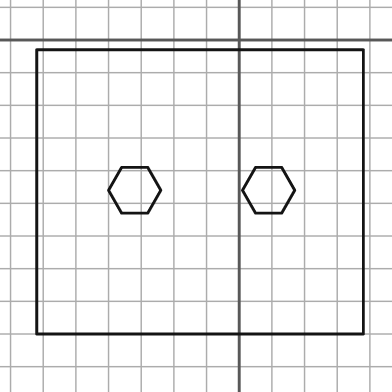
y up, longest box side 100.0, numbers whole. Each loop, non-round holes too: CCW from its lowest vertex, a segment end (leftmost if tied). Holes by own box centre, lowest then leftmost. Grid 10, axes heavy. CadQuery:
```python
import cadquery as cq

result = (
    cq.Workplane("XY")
    .moveTo(-62.0, -90.0)
    .lineTo(38.0, -90.0)
    .lineTo(38.0, -3.0)
    .lineTo(-62.0, -3.0)
    .close()
    .moveTo(-36.0, -53.0)
    .lineTo(-28.0, -53.0)
    .lineTo(-24.0, -46.0)
    .lineTo(-28.0, -39.0)
    .lineTo(-36.0, -39.0)
    .lineTo(-40.0, -46.0)
    .close()
    .moveTo(5.0, -53.0)
    .lineTo(13.0, -53.0)
    .lineTo(17.0, -46.0)
    .lineTo(13.0, -39.0)
    .lineTo(5.0, -39.0)
    .lineTo(1.0, -46.0)
    .close()
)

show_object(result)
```